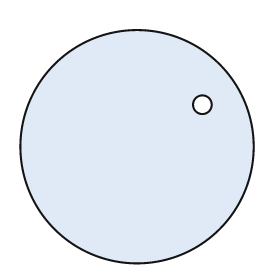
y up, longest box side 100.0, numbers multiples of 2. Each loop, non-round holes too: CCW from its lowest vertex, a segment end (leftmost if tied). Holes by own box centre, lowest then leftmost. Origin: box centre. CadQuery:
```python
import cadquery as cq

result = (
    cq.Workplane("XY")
    .moveTo(0.0, 0.0)
    .circle(50.0)
    .moveTo(28.0, 18.0)
    .circle(4.0)
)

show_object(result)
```